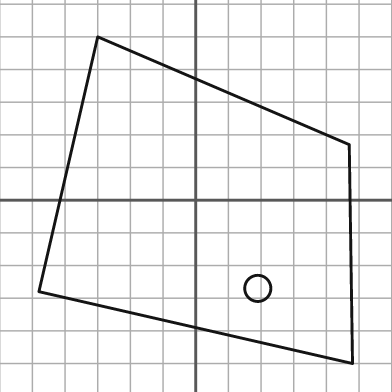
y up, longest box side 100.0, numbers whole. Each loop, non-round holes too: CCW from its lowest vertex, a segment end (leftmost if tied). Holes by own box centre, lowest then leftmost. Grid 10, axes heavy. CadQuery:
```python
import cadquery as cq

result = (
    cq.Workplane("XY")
    .moveTo(48.0, -50.0)
    .lineTo(47.0, 17.0)
    .lineTo(-30.0, 50.0)
    .lineTo(-48.0, -28.0)
    .close()
    .moveTo(19.0, -27.0)
    .circle(4.0)
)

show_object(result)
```